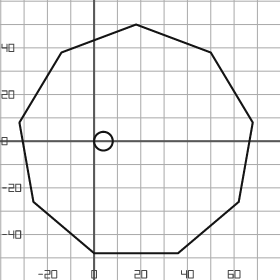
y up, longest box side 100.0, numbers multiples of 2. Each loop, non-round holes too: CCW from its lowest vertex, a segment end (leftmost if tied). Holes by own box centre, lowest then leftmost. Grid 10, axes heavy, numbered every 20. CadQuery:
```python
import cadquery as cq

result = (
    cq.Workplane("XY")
    .moveTo(0.0, -48.0)
    .lineTo(36.0, -48.0)
    .lineTo(62.0, -26.0)
    .lineTo(68.0, 8.0)
    .lineTo(50.0, 38.0)
    .lineTo(18.0, 50.0)
    .lineTo(-14.0, 38.0)
    .lineTo(-32.0, 8.0)
    .lineTo(-26.0, -26.0)
    .close()
    .moveTo(4.0, 0.0)
    .circle(4.0)
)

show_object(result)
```